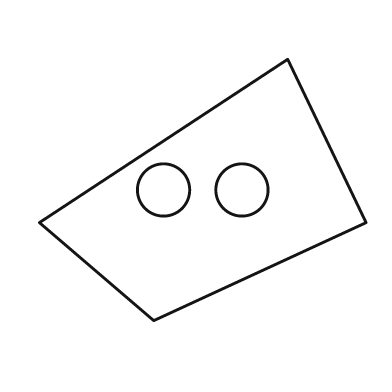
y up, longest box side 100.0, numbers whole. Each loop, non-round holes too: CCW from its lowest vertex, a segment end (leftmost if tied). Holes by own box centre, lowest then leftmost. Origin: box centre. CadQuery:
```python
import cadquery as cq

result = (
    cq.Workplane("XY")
    .moveTo(-15.0, -40.0)
    .lineTo(50.0, -10.0)
    .lineTo(26.0, 40.0)
    .lineTo(-50.0, -10.0)
    .close()
    .moveTo(-12.0, 0.0)
    .circle(8.0)
    .moveTo(12.0, 0.0)
    .circle(8.0)
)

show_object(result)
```